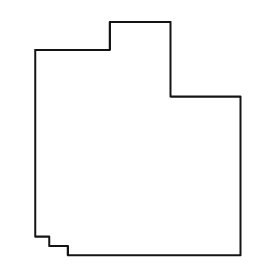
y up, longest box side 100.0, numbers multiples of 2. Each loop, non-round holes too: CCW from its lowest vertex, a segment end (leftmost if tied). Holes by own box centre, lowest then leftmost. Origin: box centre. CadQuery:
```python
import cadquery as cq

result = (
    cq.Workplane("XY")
    .moveTo(-30.0, -50.0)
    .lineTo(44.0, -50.0)
    .lineTo(44.0, 18.0)
    .lineTo(14.0, 18.0)
    .lineTo(14.0, 50.0)
    .lineTo(-12.0, 50.0)
    .lineTo(-12.0, 38.0)
    .lineTo(-44.0, 38.0)
    .lineTo(-44.0, -42.0)
    .lineTo(-38.0, -42.0)
    .lineTo(-38.0, -46.0)
    .lineTo(-30.0, -46.0)
    .close()
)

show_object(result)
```